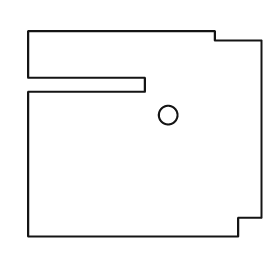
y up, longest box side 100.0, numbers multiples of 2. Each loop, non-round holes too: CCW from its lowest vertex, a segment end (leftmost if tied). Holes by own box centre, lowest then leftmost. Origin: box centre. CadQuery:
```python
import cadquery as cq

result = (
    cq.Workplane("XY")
    .moveTo(-50.0, -44.0)
    .lineTo(40.0, -44.0)
    .lineTo(40.0, -36.0)
    .lineTo(50.0, -36.0)
    .lineTo(50.0, 40.0)
    .lineTo(30.0, 40.0)
    .lineTo(30.0, 44.0)
    .lineTo(-50.0, 44.0)
    .lineTo(-50.0, 24.0)
    .lineTo(0.0, 24.0)
    .lineTo(0.0, 18.0)
    .lineTo(-50.0, 18.0)
    .close()
    .moveTo(10.0, 8.0)
    .circle(4.0)
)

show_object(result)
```